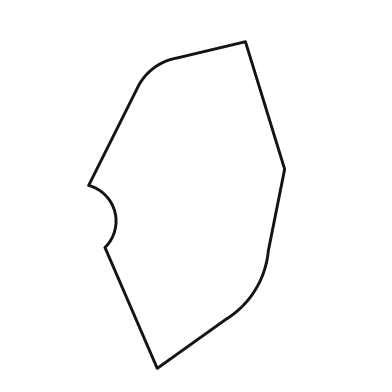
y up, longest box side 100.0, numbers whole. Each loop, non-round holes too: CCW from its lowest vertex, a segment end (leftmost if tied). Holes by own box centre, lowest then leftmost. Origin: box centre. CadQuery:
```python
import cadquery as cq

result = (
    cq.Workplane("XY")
    .moveTo(-9.0, -50.0)
    .lineTo(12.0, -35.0)
    .threePointArc((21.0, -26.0), (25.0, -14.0))
    .lineTo(30.0, 11.0)
    .lineTo(18.0, 50.0)
    .lineTo(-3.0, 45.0)
    .threePointArc((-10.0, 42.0), (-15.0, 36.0))
    .lineTo(-30.0, 6.0)
    .threePointArc((-22.0, -2.0), (-25.0, -13.0))
    .close()
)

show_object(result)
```